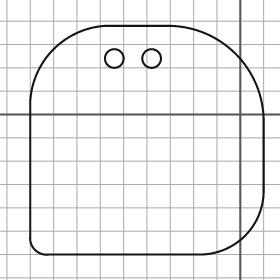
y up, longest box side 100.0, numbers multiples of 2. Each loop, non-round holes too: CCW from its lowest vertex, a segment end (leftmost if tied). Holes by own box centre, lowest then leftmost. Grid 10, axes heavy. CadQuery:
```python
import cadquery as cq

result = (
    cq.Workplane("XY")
    .moveTo(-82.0, -60.0)
    .lineTo(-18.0, -60.0)
    .threePointArc((2.0, -52.0), (10.0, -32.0))
    .lineTo(10.0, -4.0)
    .threePointArc((-2.0, 26.0), (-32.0, 38.0))
    .lineTo(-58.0, 38.0)
    .threePointArc((-80.0, 28.0), (-90.0, 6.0))
    .lineTo(-90.0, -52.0)
    .threePointArc((-88.0, -58.0), (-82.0, -60.0))
    .close()
    .moveTo(-54.0, 24.0)
    .circle(4.0)
    .moveTo(-38.0, 24.0)
    .circle(4.0)
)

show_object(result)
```